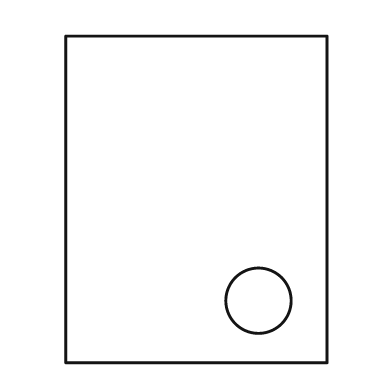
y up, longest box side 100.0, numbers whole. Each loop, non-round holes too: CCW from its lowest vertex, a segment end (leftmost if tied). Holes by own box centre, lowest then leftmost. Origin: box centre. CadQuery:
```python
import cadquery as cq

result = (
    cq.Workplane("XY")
    .moveTo(-40.0, -50.0)
    .lineTo(40.0, -50.0)
    .lineTo(40.0, 50.0)
    .lineTo(-40.0, 50.0)
    .close()
    .moveTo(19.0, -31.0)
    .circle(10.0)
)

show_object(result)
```